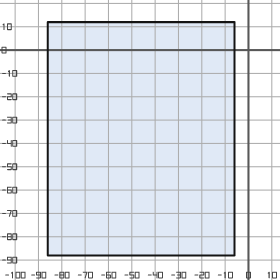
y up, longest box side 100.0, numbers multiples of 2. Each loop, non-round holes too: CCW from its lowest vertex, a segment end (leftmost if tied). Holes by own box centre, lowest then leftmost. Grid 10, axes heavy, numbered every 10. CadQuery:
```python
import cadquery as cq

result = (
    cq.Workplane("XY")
    .moveTo(-86.0, -88.0)
    .lineTo(-6.0, -88.0)
    .lineTo(-6.0, 12.0)
    .lineTo(-86.0, 12.0)
    .close()
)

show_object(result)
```